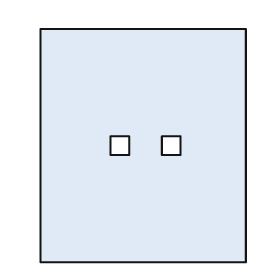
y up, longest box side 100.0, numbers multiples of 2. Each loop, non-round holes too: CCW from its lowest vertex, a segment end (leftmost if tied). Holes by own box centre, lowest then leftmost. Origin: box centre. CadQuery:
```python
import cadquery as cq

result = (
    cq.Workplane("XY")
    .moveTo(-44.0, -50.0)
    .lineTo(44.0, -50.0)
    .lineTo(44.0, 50.0)
    .lineTo(-44.0, 50.0)
    .close()
    .moveTo(-14.0, -4.0)
    .lineTo(-6.0, -4.0)
    .lineTo(-6.0, 4.0)
    .lineTo(-14.0, 4.0)
    .close()
    .moveTo(8.0, -4.0)
    .lineTo(16.0, -4.0)
    .lineTo(16.0, 4.0)
    .lineTo(8.0, 4.0)
    .close()
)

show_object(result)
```